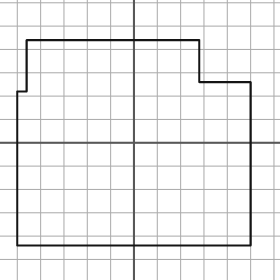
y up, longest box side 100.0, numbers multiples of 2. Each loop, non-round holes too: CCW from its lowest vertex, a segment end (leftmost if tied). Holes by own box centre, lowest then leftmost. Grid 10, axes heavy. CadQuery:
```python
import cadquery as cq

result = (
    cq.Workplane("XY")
    .moveTo(-50.0, -44.0)
    .lineTo(50.0, -44.0)
    .lineTo(50.0, 26.0)
    .lineTo(28.0, 26.0)
    .lineTo(28.0, 44.0)
    .lineTo(-46.0, 44.0)
    .lineTo(-46.0, 22.0)
    .lineTo(-50.0, 22.0)
    .close()
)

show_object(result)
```